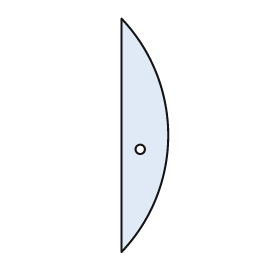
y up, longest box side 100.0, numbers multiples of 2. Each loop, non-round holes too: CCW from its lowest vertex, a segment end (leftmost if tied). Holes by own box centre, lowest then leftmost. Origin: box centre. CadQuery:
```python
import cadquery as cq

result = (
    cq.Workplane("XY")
    .moveTo(-10.0, -50.0)
    .threePointArc((10.0, 0.0), (-10.0, 50.0))
    .close()
    .moveTo(-2.0, -6.0)
    .circle(2.0)
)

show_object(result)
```